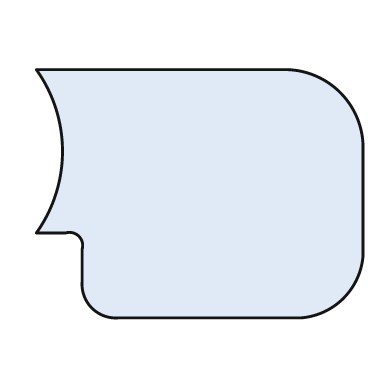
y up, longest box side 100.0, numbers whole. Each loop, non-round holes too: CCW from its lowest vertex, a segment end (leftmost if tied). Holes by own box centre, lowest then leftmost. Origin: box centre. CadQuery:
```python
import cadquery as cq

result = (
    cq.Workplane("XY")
    .moveTo(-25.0, -38.0)
    .lineTo(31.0, -38.0)
    .threePointArc((44.0, -32.0), (50.0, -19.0))
    .lineTo(50.0, 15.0)
    .threePointArc((43.0, 31.0), (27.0, 38.0))
    .lineTo(-50.0, 38.0)
    .threePointArc((-42.0, 13.0), (-50.0, -12.0))
    .lineTo(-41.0, -12.0)
    .threePointArc((-37.0, -13.0), (-36.0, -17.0))
    .lineTo(-36.0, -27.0)
    .threePointArc((-33.0, -35.0), (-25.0, -38.0))
    .close()
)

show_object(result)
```